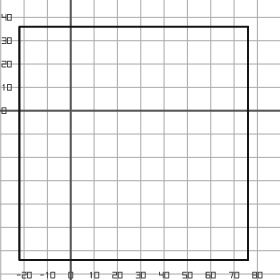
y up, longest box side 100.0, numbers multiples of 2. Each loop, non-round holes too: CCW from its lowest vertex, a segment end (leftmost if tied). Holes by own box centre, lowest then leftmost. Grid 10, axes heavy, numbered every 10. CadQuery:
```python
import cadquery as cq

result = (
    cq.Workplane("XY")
    .moveTo(-22.0, -64.0)
    .lineTo(76.0, -64.0)
    .lineTo(76.0, 36.0)
    .lineTo(-22.0, 36.0)
    .close()
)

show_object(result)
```